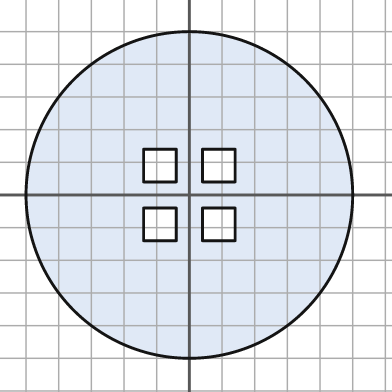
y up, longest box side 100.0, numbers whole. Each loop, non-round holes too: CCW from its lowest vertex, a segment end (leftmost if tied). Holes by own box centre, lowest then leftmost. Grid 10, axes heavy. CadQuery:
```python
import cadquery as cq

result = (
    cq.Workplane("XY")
    .moveTo(0.0, 0.0)
    .circle(50.0)
    .moveTo(-14.0, -14.0)
    .lineTo(-4.0, -14.0)
    .lineTo(-4.0, -4.0)
    .lineTo(-14.0, -4.0)
    .close()
    .moveTo(4.0, -14.0)
    .lineTo(14.0, -14.0)
    .lineTo(14.0, -4.0)
    .lineTo(4.0, -4.0)
    .close()
    .moveTo(-14.0, 4.0)
    .lineTo(-4.0, 4.0)
    .lineTo(-4.0, 14.0)
    .lineTo(-14.0, 14.0)
    .close()
    .moveTo(4.0, 4.0)
    .lineTo(14.0, 4.0)
    .lineTo(14.0, 14.0)
    .lineTo(4.0, 14.0)
    .close()
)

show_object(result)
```